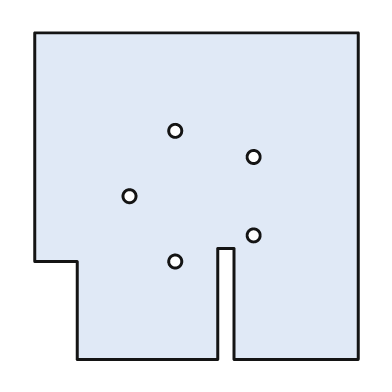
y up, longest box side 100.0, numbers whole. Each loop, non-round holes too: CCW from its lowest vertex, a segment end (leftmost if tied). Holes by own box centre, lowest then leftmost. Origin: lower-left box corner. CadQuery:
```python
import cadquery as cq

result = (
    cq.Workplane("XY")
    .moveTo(13.0, 0.0)
    .lineTo(56.0, 0.0)
    .lineTo(56.0, 34.0)
    .lineTo(61.0, 34.0)
    .lineTo(61.0, 0.0)
    .lineTo(99.0, 0.0)
    .lineTo(99.0, 100.0)
    .lineTo(0.0, 100.0)
    .lineTo(0.0, 30.0)
    .lineTo(13.0, 30.0)
    .close()
    .moveTo(43.0, 30.0)
    .circle(2.0)
    .moveTo(67.0, 38.0)
    .circle(2.0)
    .moveTo(29.0, 50.0)
    .circle(2.0)
    .moveTo(67.0, 62.0)
    .circle(2.0)
    .moveTo(43.0, 70.0)
    .circle(2.0)
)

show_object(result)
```